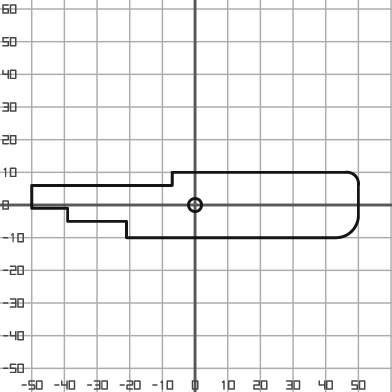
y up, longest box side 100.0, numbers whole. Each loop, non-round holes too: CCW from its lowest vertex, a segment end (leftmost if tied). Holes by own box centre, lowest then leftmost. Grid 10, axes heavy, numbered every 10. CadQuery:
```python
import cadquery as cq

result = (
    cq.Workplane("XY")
    .moveTo(-21.0, -10.0)
    .lineTo(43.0, -10.0)
    .threePointArc((48.0, -8.0), (50.0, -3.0))
    .lineTo(50.0, 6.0)
    .threePointArc((49.0, 9.0), (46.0, 10.0))
    .lineTo(-7.0, 10.0)
    .lineTo(-7.0, 6.0)
    .lineTo(-50.0, 6.0)
    .lineTo(-50.0, -1.0)
    .lineTo(-39.0, -1.0)
    .lineTo(-39.0, -5.0)
    .lineTo(-21.0, -5.0)
    .close()
    .moveTo(0.0, 0.0)
    .circle(2.0)
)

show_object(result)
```